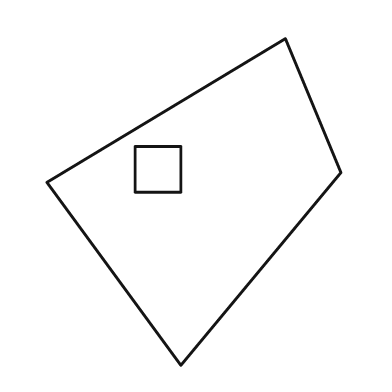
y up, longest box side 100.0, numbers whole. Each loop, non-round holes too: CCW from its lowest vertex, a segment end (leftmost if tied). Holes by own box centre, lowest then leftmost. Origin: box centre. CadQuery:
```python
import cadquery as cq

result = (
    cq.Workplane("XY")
    .moveTo(-4.0, -50.0)
    .lineTo(45.0, 9.0)
    .lineTo(28.0, 50.0)
    .lineTo(-45.0, 6.0)
    .close()
    .moveTo(-18.0, 3.0)
    .lineTo(-4.0, 3.0)
    .lineTo(-4.0, 17.0)
    .lineTo(-18.0, 17.0)
    .close()
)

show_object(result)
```